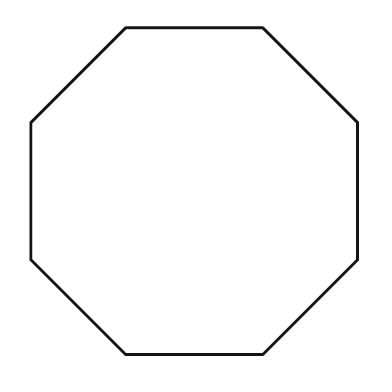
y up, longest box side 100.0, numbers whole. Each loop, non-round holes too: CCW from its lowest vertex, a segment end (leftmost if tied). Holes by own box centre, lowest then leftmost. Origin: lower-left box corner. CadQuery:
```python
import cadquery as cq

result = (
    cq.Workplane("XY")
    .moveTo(29.0, 0.0)
    .lineTo(71.0, 0.0)
    .lineTo(100.0, 29.0)
    .lineTo(100.0, 71.0)
    .lineTo(71.0, 100.0)
    .lineTo(29.0, 100.0)
    .lineTo(0.0, 71.0)
    .lineTo(0.0, 29.0)
    .close()
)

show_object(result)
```